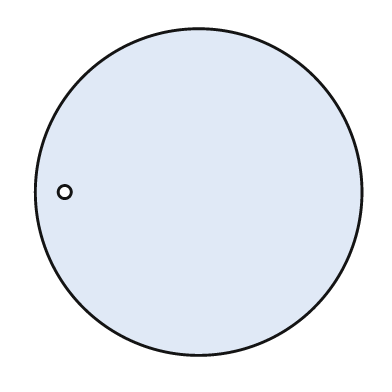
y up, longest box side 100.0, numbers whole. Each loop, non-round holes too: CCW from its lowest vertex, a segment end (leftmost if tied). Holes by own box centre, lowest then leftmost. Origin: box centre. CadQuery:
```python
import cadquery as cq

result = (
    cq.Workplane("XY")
    .moveTo(0.0, 0.0)
    .circle(50.0)
    .moveTo(-41.0, 0.0)
    .circle(2.0)
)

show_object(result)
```